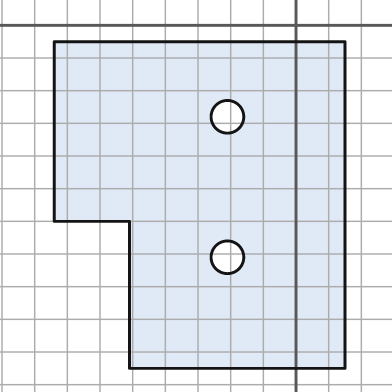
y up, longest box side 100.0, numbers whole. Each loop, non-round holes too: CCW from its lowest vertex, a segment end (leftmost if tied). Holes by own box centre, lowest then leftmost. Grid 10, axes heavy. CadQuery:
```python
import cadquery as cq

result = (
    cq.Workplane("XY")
    .moveTo(-51.0, -105.0)
    .lineTo(15.0, -105.0)
    .lineTo(15.0, -5.0)
    .lineTo(-74.0, -5.0)
    .lineTo(-74.0, -60.0)
    .lineTo(-51.0, -60.0)
    .close()
    .moveTo(-21.0, -71.0)
    .circle(5.0)
    .moveTo(-21.0, -28.0)
    .circle(5.0)
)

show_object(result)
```